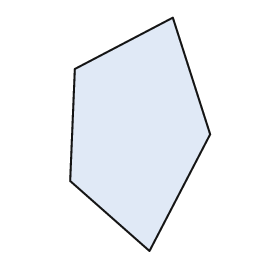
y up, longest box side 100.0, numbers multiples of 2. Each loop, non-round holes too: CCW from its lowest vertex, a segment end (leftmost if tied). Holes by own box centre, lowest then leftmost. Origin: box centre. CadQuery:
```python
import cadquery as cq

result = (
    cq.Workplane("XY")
    .moveTo(4.0, -50.0)
    .lineTo(30.0, 0.0)
    .lineTo(14.0, 50.0)
    .lineTo(-28.0, 28.0)
    .lineTo(-30.0, -20.0)
    .close()
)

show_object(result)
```